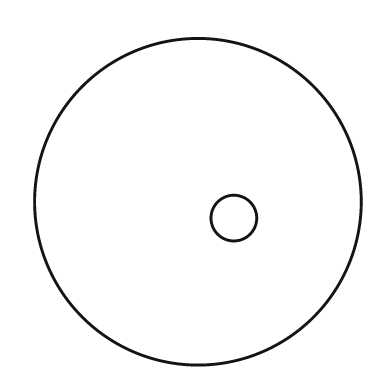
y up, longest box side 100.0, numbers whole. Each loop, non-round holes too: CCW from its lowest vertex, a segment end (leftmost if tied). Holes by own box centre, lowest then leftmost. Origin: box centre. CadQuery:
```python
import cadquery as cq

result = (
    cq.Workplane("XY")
    .moveTo(0.0, 0.0)
    .circle(50.0)
    .moveTo(11.0, -5.0)
    .circle(7.0)
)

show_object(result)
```